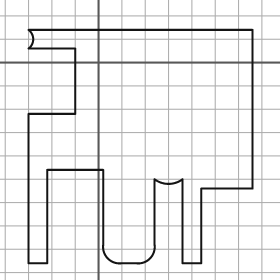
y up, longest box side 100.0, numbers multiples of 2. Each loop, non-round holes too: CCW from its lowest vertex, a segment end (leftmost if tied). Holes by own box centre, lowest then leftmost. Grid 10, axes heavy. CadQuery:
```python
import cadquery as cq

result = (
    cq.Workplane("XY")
    .moveTo(-30.0, -86.0)
    .lineTo(-22.0, -86.0)
    .lineTo(-22.0, -46.0)
    .lineTo(2.0, -46.0)
    .lineTo(2.0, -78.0)
    .threePointArc((4.0, -84.0), (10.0, -86.0))
    .lineTo(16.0, -86.0)
    .threePointArc((22.0, -84.0), (24.0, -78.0))
    .lineTo(24.0, -50.0)
    .threePointArc((30.0, -52.0), (36.0, -50.0))
    .lineTo(36.0, -86.0)
    .lineTo(44.0, -86.0)
    .lineTo(44.0, -54.0)
    .lineTo(66.0, -54.0)
    .lineTo(66.0, 14.0)
    .lineTo(-30.0, 14.0)
    .threePointArc((-28.0, 10.0), (-30.0, 6.0))
    .lineTo(-10.0, 6.0)
    .lineTo(-10.0, -22.0)
    .lineTo(-30.0, -22.0)
    .close()
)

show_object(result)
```